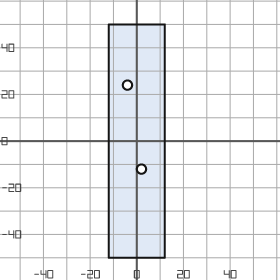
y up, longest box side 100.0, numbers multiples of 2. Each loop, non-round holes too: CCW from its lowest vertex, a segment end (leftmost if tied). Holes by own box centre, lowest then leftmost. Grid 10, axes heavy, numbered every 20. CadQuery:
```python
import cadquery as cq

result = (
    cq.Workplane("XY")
    .moveTo(-12.0, -50.0)
    .lineTo(12.0, -50.0)
    .lineTo(12.0, 50.0)
    .lineTo(-12.0, 50.0)
    .close()
    .moveTo(2.0, -12.0)
    .circle(2.0)
    .moveTo(-4.0, 24.0)
    .circle(2.0)
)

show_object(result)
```